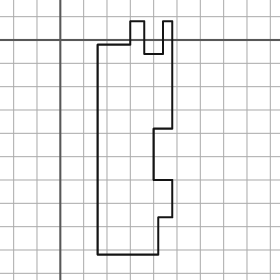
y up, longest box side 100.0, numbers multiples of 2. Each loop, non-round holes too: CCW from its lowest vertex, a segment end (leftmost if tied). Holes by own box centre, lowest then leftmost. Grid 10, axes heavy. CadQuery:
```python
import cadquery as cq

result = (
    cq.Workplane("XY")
    .moveTo(16.0, -92.0)
    .lineTo(42.0, -92.0)
    .lineTo(42.0, -76.0)
    .lineTo(48.0, -76.0)
    .lineTo(48.0, -60.0)
    .lineTo(40.0, -60.0)
    .lineTo(40.0, -38.0)
    .lineTo(48.0, -38.0)
    .lineTo(48.0, 8.0)
    .lineTo(44.0, 8.0)
    .lineTo(44.0, -6.0)
    .lineTo(36.0, -6.0)
    .lineTo(36.0, 8.0)
    .lineTo(30.0, 8.0)
    .lineTo(30.0, -2.0)
    .lineTo(16.0, -2.0)
    .close()
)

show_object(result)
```